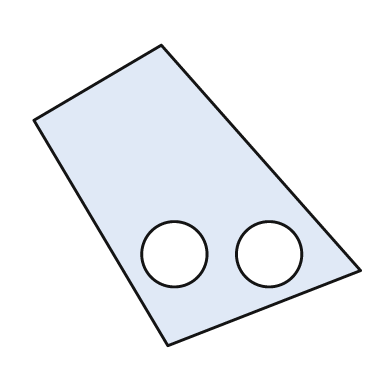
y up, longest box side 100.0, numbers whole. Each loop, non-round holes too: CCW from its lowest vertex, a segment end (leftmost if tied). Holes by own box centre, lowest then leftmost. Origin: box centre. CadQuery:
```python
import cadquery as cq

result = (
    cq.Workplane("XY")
    .moveTo(-9.0, -46.0)
    .lineTo(50.0, -23.0)
    .lineTo(-11.0, 46.0)
    .lineTo(-50.0, 23.0)
    .close()
    .moveTo(-7.0, -18.0)
    .circle(10.0)
    .moveTo(22.0, -18.0)
    .circle(10.0)
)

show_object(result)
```